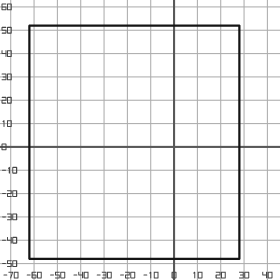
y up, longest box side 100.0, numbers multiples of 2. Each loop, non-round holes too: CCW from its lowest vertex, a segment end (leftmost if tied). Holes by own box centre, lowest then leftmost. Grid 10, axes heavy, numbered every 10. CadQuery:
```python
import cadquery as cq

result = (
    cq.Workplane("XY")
    .moveTo(-62.0, -48.0)
    .lineTo(28.0, -48.0)
    .lineTo(28.0, 52.0)
    .lineTo(-62.0, 52.0)
    .close()
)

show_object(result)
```